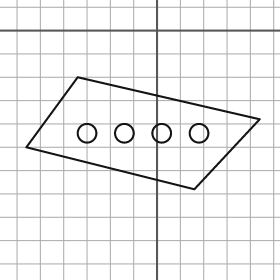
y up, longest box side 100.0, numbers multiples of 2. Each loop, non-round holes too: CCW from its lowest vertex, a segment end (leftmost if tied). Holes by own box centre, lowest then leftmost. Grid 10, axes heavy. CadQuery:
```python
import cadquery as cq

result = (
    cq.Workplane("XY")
    .moveTo(16.0, -68.0)
    .lineTo(44.0, -38.0)
    .lineTo(-34.0, -20.0)
    .lineTo(-56.0, -50.0)
    .close()
    .moveTo(-30.0, -44.0)
    .circle(4.0)
    .moveTo(-14.0, -44.0)
    .circle(4.0)
    .moveTo(2.0, -44.0)
    .circle(4.0)
    .moveTo(18.0, -44.0)
    .circle(4.0)
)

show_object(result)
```